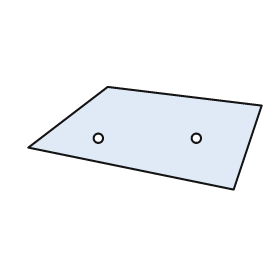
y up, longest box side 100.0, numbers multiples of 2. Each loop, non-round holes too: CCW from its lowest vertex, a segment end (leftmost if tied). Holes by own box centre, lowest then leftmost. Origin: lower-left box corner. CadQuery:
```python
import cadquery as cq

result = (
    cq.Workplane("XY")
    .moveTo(88.0, 0.0)
    .lineTo(100.0, 36.0)
    .lineTo(34.0, 44.0)
    .lineTo(0.0, 18.0)
    .close()
    .moveTo(30.0, 22.0)
    .circle(2.0)
    .moveTo(72.0, 22.0)
    .circle(2.0)
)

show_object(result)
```